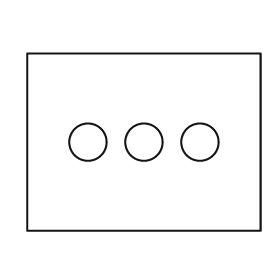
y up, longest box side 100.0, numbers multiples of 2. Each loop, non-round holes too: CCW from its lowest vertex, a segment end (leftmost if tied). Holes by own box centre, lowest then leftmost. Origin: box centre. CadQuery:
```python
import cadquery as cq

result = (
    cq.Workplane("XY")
    .moveTo(-50.0, -38.0)
    .lineTo(50.0, -38.0)
    .lineTo(50.0, 38.0)
    .lineTo(-50.0, 38.0)
    .close()
    .moveTo(-24.0, 0.0)
    .circle(8.0)
    .moveTo(0.0, 0.0)
    .circle(8.0)
    .moveTo(24.0, 0.0)
    .circle(8.0)
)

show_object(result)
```